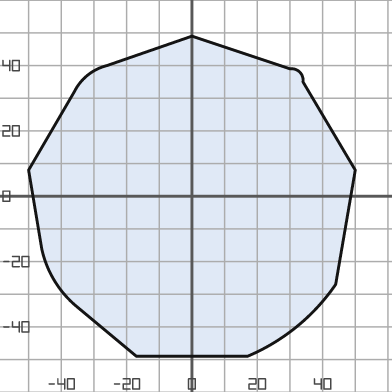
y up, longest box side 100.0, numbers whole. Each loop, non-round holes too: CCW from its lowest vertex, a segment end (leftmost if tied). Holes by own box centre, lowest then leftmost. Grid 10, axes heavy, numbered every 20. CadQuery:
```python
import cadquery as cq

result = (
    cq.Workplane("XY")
    .moveTo(-17.0, -49.0)
    .lineTo(17.0, -49.0)
    .threePointArc((32.0, -40.0), (44.0, -27.0))
    .lineTo(50.0, 8.0)
    .lineTo(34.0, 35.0)
    .threePointArc((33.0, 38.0), (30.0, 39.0))
    .lineTo(0.0, 49.0)
    .lineTo(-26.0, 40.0)
    .threePointArc((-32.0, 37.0), (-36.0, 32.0))
    .lineTo(-50.0, 8.0)
    .lineTo(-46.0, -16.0)
    .threePointArc((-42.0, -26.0), (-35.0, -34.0))
    .close()
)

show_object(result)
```